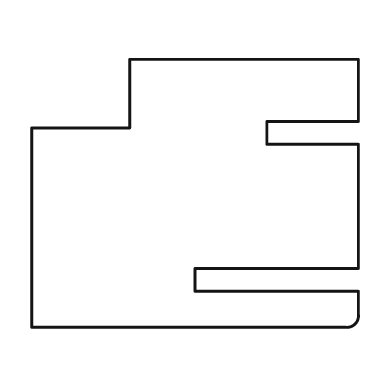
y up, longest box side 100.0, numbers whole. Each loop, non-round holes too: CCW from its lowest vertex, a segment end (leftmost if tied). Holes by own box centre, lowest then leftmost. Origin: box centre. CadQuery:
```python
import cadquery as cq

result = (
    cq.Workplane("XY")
    .moveTo(-50.0, -41.0)
    .lineTo(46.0, -41.0)
    .threePointArc((49.0, -40.0), (50.0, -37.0))
    .lineTo(50.0, -30.0)
    .lineTo(0.0, -30.0)
    .lineTo(0.0, -23.0)
    .lineTo(50.0, -23.0)
    .lineTo(50.0, 15.0)
    .lineTo(22.0, 15.0)
    .lineTo(22.0, 22.0)
    .lineTo(50.0, 22.0)
    .lineTo(50.0, 41.0)
    .lineTo(-20.0, 41.0)
    .lineTo(-20.0, 20.0)
    .lineTo(-50.0, 20.0)
    .close()
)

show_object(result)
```